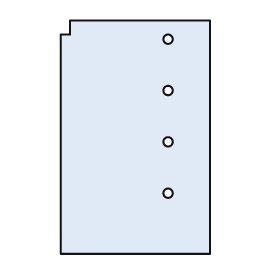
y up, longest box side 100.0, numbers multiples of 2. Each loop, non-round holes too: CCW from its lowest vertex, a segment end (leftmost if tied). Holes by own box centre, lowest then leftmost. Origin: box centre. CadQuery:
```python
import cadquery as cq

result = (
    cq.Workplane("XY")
    .moveTo(-32.0, -50.0)
    .lineTo(32.0, -50.0)
    .lineTo(32.0, 50.0)
    .lineTo(-28.0, 50.0)
    .lineTo(-28.0, 44.0)
    .lineTo(-32.0, 44.0)
    .close()
    .moveTo(14.0, -24.0)
    .circle(2.0)
    .moveTo(14.0, -2.0)
    .circle(2.0)
    .moveTo(14.0, 20.0)
    .circle(2.0)
    .moveTo(14.0, 42.0)
    .circle(2.0)
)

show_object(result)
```